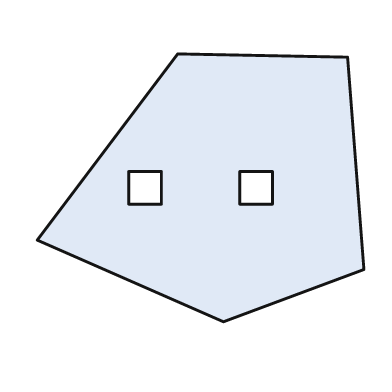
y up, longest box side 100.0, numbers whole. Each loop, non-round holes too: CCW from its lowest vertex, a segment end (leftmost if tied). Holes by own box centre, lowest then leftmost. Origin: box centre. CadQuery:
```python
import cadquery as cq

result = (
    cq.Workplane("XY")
    .moveTo(7.0, -41.0)
    .lineTo(50.0, -25.0)
    .lineTo(45.0, 40.0)
    .lineTo(-7.0, 41.0)
    .lineTo(-50.0, -16.0)
    .close()
    .moveTo(-22.0, -5.0)
    .lineTo(-12.0, -5.0)
    .lineTo(-12.0, 5.0)
    .lineTo(-22.0, 5.0)
    .close()
    .moveTo(12.0, -5.0)
    .lineTo(22.0, -5.0)
    .lineTo(22.0, 5.0)
    .lineTo(12.0, 5.0)
    .close()
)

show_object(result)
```